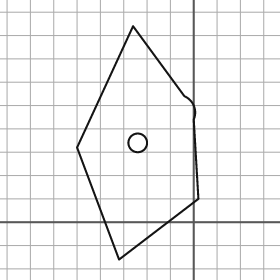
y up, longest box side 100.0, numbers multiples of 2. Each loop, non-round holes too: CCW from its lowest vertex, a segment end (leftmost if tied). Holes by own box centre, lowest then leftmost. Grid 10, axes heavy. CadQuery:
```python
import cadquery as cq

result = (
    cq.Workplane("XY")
    .moveTo(-32.0, -16.0)
    .lineTo(2.0, 10.0)
    .lineTo(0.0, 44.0)
    .threePointArc((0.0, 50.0), (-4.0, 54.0))
    .lineTo(-26.0, 84.0)
    .lineTo(-50.0, 32.0)
    .close()
    .moveTo(-24.0, 34.0)
    .circle(4.0)
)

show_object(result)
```